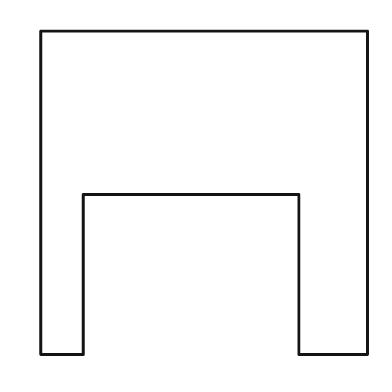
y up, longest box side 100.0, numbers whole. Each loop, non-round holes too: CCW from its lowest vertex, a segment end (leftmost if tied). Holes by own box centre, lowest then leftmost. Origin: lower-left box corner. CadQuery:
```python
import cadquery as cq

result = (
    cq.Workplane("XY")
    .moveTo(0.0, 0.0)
    .lineTo(13.0, 0.0)
    .lineTo(13.0, 49.0)
    .lineTo(79.0, 49.0)
    .lineTo(79.0, 0.0)
    .lineTo(100.0, 0.0)
    .lineTo(100.0, 99.0)
    .lineTo(0.0, 99.0)
    .close()
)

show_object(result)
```